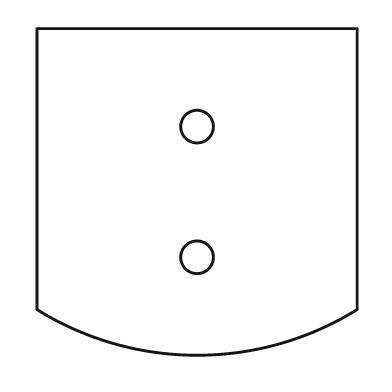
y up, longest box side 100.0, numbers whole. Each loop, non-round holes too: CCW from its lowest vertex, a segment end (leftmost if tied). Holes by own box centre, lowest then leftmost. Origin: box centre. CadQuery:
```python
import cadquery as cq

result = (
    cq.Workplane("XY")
    .moveTo(-49.0, -36.0)
    .threePointArc((0.0, -50.0), (49.0, -36.0))
    .lineTo(49.0, 50.0)
    .lineTo(-49.0, 50.0)
    .close()
    .moveTo(0.0, -20.0)
    .circle(5.0)
    .moveTo(0.0, 20.0)
    .circle(5.0)
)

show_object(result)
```